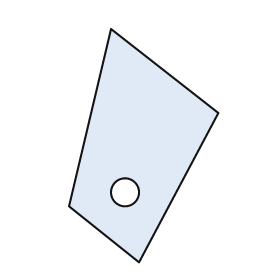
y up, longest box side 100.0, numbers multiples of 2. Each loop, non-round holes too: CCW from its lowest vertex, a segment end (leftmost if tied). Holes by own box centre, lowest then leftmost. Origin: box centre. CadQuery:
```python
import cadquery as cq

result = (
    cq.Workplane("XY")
    .moveTo(-2.0, -50.0)
    .lineTo(32.0, 14.0)
    .lineTo(-14.0, 50.0)
    .lineTo(-32.0, -26.0)
    .close()
    .moveTo(-8.0, -20.0)
    .circle(6.0)
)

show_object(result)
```